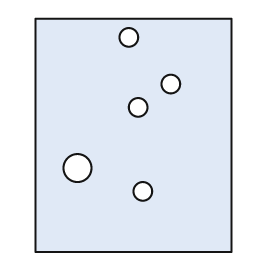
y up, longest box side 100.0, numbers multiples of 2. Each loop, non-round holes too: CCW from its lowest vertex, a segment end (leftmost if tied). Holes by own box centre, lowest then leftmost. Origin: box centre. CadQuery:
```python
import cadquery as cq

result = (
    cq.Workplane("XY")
    .moveTo(-42.0, -50.0)
    .lineTo(42.0, -50.0)
    .lineTo(42.0, 50.0)
    .lineTo(-42.0, 50.0)
    .close()
    .moveTo(4.0, -24.0)
    .circle(4.0)
    .moveTo(-24.0, -14.0)
    .circle(6.0)
    .moveTo(2.0, 12.0)
    .circle(4.0)
    .moveTo(16.0, 22.0)
    .circle(4.0)
    .moveTo(-2.0, 42.0)
    .circle(4.0)
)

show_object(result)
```